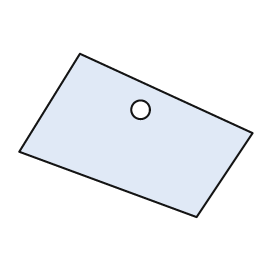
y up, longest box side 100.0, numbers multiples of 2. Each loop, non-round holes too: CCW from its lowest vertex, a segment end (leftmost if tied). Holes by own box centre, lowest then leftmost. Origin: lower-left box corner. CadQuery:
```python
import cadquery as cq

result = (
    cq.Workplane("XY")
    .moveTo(76.0, 0.0)
    .lineTo(100.0, 36.0)
    .lineTo(26.0, 70.0)
    .lineTo(0.0, 28.0)
    .close()
    .moveTo(52.0, 46.0)
    .circle(4.0)
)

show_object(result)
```